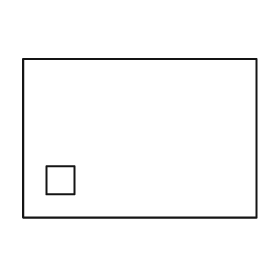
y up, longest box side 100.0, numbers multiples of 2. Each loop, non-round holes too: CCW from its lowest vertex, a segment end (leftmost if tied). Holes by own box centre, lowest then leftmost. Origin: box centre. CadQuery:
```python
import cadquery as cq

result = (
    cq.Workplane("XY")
    .moveTo(-50.0, -34.0)
    .lineTo(50.0, -34.0)
    .lineTo(50.0, 34.0)
    .lineTo(-50.0, 34.0)
    .close()
    .moveTo(-40.0, -24.0)
    .lineTo(-28.0, -24.0)
    .lineTo(-28.0, -12.0)
    .lineTo(-40.0, -12.0)
    .close()
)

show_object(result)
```